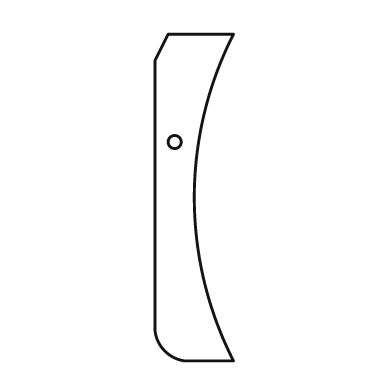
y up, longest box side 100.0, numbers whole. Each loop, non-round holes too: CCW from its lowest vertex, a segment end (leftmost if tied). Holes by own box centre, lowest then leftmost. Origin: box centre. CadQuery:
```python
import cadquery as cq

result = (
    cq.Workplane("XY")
    .moveTo(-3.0, -50.0)
    .lineTo(12.0, -50.0)
    .threePointArc((0.0, 0.0), (12.0, 50.0))
    .lineTo(-8.0, 50.0)
    .lineTo(-12.0, 42.0)
    .lineTo(-12.0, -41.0)
    .threePointArc((-9.0, -47.0), (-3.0, -50.0))
    .close()
    .moveTo(-6.0, 17.0)
    .circle(2.0)
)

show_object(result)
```